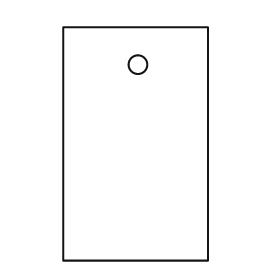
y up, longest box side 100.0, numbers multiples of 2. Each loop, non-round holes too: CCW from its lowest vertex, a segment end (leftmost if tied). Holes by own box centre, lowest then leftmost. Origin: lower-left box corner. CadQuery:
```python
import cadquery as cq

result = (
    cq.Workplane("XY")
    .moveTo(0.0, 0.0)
    .lineTo(62.0, 0.0)
    .lineTo(62.0, 100.0)
    .lineTo(0.0, 100.0)
    .close()
    .moveTo(32.0, 84.0)
    .circle(4.0)
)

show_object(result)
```